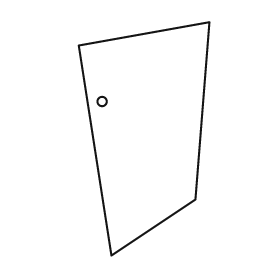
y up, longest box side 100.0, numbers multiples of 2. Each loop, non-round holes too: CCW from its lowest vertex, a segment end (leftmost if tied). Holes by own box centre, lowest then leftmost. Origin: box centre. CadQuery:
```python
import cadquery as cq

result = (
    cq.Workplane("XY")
    .moveTo(-14.0, -50.0)
    .lineTo(22.0, -26.0)
    .lineTo(28.0, 50.0)
    .lineTo(-28.0, 40.0)
    .close()
    .moveTo(-18.0, 16.0)
    .circle(2.0)
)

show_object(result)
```